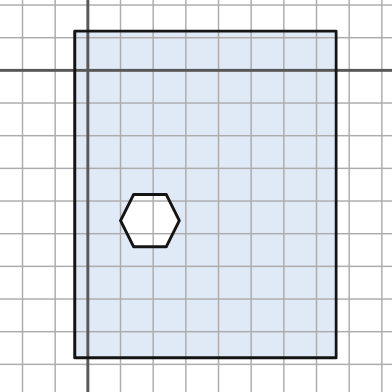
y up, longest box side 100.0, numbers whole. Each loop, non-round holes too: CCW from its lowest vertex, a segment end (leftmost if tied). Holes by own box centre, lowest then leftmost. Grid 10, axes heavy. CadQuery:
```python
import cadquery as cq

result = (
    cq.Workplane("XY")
    .moveTo(-4.0, -88.0)
    .lineTo(76.0, -88.0)
    .lineTo(76.0, 12.0)
    .lineTo(-4.0, 12.0)
    .close()
    .moveTo(14.0, -54.0)
    .lineTo(24.0, -54.0)
    .lineTo(28.0, -46.0)
    .lineTo(24.0, -38.0)
    .lineTo(14.0, -38.0)
    .lineTo(10.0, -46.0)
    .close()
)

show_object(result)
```